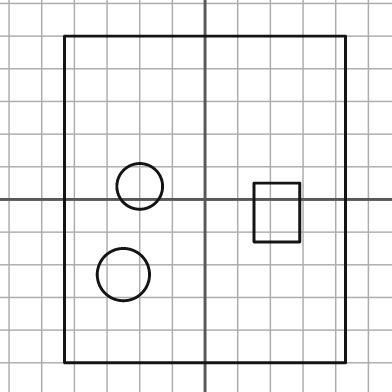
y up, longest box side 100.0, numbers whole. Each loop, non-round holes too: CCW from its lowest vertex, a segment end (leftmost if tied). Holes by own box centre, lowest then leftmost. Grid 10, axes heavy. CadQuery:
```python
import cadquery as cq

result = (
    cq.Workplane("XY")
    .moveTo(-43.0, -50.0)
    .lineTo(43.0, -50.0)
    .lineTo(43.0, 50.0)
    .lineTo(-43.0, 50.0)
    .close()
    .moveTo(-25.0, -23.0)
    .circle(8.0)
    .moveTo(15.0, -13.0)
    .lineTo(29.0, -13.0)
    .lineTo(29.0, 5.0)
    .lineTo(15.0, 5.0)
    .close()
    .moveTo(-20.0, 4.0)
    .circle(7.0)
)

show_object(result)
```